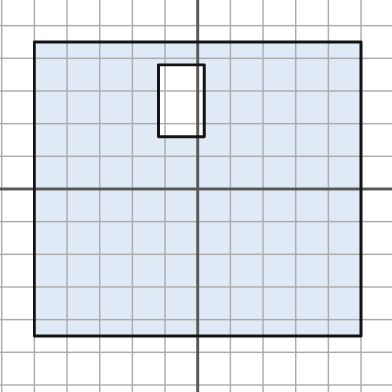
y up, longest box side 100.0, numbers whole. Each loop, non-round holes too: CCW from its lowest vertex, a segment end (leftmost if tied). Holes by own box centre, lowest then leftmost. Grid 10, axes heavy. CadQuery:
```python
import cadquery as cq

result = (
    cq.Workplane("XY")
    .moveTo(-50.0, -45.0)
    .lineTo(50.0, -45.0)
    .lineTo(50.0, 45.0)
    .lineTo(-50.0, 45.0)
    .close()
    .moveTo(-12.0, 16.0)
    .lineTo(2.0, 16.0)
    .lineTo(2.0, 38.0)
    .lineTo(-12.0, 38.0)
    .close()
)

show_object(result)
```